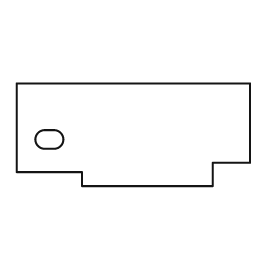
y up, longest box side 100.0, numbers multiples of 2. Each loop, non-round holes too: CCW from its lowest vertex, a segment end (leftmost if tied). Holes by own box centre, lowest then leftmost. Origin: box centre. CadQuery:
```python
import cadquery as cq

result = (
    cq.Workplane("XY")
    .moveTo(-22.0, -22.0)
    .lineTo(34.0, -22.0)
    .lineTo(34.0, -12.0)
    .lineTo(50.0, -12.0)
    .lineTo(50.0, 22.0)
    .lineTo(-50.0, 22.0)
    .lineTo(-50.0, -16.0)
    .lineTo(-22.0, -16.0)
    .close()
    .moveTo(-38.0, -6.0)
    .lineTo(-34.0, -6.0)
    .threePointArc((-30.0, -2.0), (-34.0, 2.0))
    .lineTo(-38.0, 2.0)
    .threePointArc((-42.0, -2.0), (-38.0, -6.0))
    .close()
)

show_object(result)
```